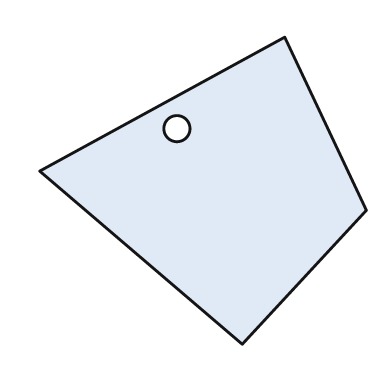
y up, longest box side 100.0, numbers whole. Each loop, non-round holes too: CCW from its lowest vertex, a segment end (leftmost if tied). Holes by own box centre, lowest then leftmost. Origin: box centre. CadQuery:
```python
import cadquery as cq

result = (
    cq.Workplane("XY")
    .moveTo(12.0, -47.0)
    .lineTo(50.0, -6.0)
    .lineTo(25.0, 47.0)
    .lineTo(-50.0, 6.0)
    .close()
    .moveTo(-8.0, 19.0)
    .circle(4.0)
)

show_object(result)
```